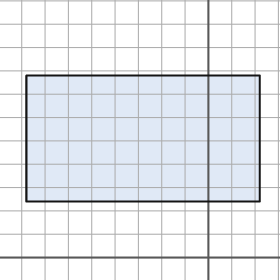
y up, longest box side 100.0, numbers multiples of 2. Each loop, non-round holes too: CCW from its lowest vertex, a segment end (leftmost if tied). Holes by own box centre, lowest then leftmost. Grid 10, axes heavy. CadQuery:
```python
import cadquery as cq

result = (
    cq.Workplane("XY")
    .moveTo(-78.0, 24.0)
    .lineTo(22.0, 24.0)
    .lineTo(22.0, 78.0)
    .lineTo(-78.0, 78.0)
    .close()
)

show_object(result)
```